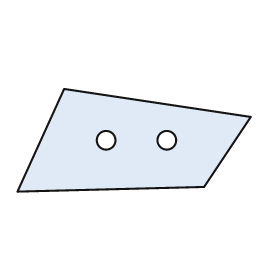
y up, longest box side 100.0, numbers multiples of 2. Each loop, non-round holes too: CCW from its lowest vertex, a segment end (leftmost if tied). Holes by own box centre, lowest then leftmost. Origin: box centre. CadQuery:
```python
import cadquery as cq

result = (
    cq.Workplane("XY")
    .moveTo(-50.0, -22.0)
    .lineTo(30.0, -20.0)
    .lineTo(50.0, 10.0)
    .lineTo(-30.0, 22.0)
    .close()
    .moveTo(-12.0, 0.0)
    .circle(4.0)
    .moveTo(14.0, 0.0)
    .circle(4.0)
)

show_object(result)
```